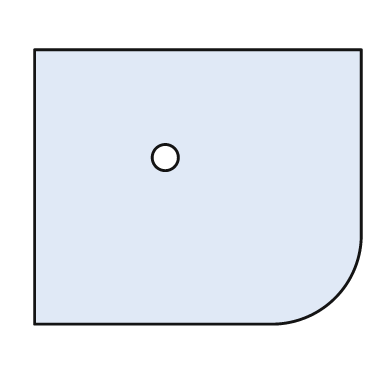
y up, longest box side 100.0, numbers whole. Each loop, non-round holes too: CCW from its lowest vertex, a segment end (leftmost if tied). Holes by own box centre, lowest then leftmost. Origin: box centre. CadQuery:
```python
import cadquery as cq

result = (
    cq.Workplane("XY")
    .moveTo(-50.0, -42.0)
    .lineTo(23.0, -42.0)
    .threePointArc((42.0, -34.0), (50.0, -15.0))
    .lineTo(50.0, 42.0)
    .lineTo(-50.0, 42.0)
    .close()
    .moveTo(-10.0, 9.0)
    .circle(4.0)
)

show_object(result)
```